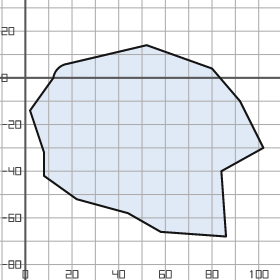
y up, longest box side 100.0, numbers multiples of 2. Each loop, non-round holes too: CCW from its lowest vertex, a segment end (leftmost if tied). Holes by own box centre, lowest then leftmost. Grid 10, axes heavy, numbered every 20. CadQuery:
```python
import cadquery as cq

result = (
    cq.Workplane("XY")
    .moveTo(86.0, -68.0)
    .lineTo(84.0, -40.0)
    .lineTo(102.0, -30.0)
    .lineTo(92.0, -10.0)
    .lineTo(80.0, 4.0)
    .lineTo(52.0, 14.0)
    .lineTo(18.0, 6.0)
    .threePointArc((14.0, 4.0), (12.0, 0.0))
    .lineTo(2.0, -14.0)
    .lineTo(8.0, -32.0)
    .lineTo(8.0, -42.0)
    .lineTo(22.0, -52.0)
    .lineTo(44.0, -58.0)
    .lineTo(58.0, -66.0)
    .close()
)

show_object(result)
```